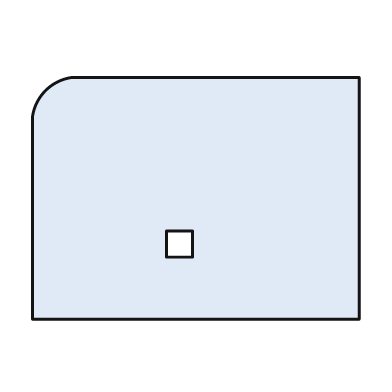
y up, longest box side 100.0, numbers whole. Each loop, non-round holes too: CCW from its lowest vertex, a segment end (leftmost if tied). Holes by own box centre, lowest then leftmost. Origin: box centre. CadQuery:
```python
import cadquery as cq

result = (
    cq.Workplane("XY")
    .moveTo(-50.0, -37.0)
    .lineTo(50.0, -37.0)
    .lineTo(50.0, 37.0)
    .lineTo(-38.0, 37.0)
    .threePointArc((-46.0, 33.0), (-50.0, 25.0))
    .close()
    .moveTo(-9.0, -18.0)
    .lineTo(-1.0, -18.0)
    .lineTo(-1.0, -10.0)
    .lineTo(-9.0, -10.0)
    .close()
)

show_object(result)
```